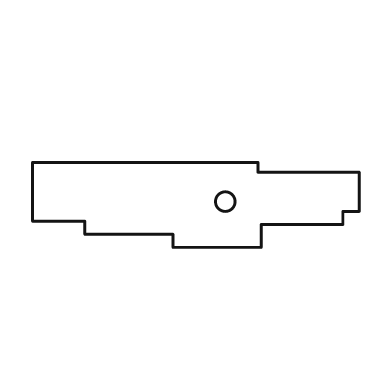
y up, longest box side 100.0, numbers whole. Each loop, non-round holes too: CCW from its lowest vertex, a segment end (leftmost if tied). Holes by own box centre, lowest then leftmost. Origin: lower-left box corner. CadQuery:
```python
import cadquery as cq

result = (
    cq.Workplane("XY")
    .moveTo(43.0, 0.0)
    .lineTo(70.0, 0.0)
    .lineTo(70.0, 7.0)
    .lineTo(95.0, 7.0)
    .lineTo(95.0, 11.0)
    .lineTo(100.0, 11.0)
    .lineTo(100.0, 23.0)
    .lineTo(69.0, 23.0)
    .lineTo(69.0, 26.0)
    .lineTo(0.0, 26.0)
    .lineTo(0.0, 8.0)
    .lineTo(16.0, 8.0)
    .lineTo(16.0, 4.0)
    .lineTo(43.0, 4.0)
    .close()
    .moveTo(59.0, 14.0)
    .circle(3.0)
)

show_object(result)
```